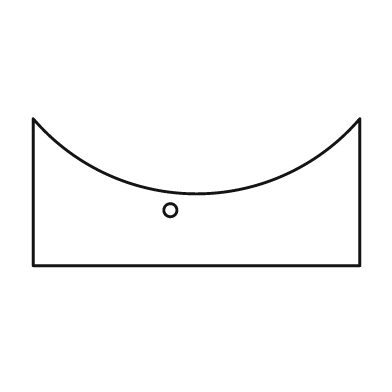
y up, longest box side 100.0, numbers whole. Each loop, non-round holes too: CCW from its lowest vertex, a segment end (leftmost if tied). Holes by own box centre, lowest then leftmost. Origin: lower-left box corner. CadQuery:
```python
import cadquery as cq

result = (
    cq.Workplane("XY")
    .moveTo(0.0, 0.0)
    .lineTo(100.0, 0.0)
    .lineTo(100.0, 45.0)
    .threePointArc((50.0, 22.0), (0.0, 45.0))
    .close()
    .moveTo(42.0, 17.0)
    .circle(2.0)
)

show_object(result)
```